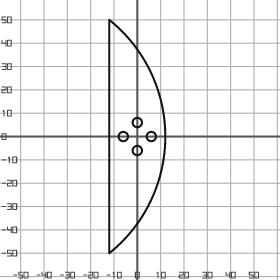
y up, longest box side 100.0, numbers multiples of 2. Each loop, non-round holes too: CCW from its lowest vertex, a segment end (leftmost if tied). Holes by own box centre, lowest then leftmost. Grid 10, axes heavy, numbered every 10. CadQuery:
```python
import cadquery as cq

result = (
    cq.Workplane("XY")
    .moveTo(-12.0, -50.0)
    .threePointArc((12.0, 0.0), (-12.0, 50.0))
    .close()
    .moveTo(0.0, -6.0)
    .circle(2.0)
    .moveTo(-6.0, 0.0)
    .circle(2.0)
    .moveTo(6.0, 0.0)
    .circle(2.0)
    .moveTo(0.0, 6.0)
    .circle(2.0)
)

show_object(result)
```